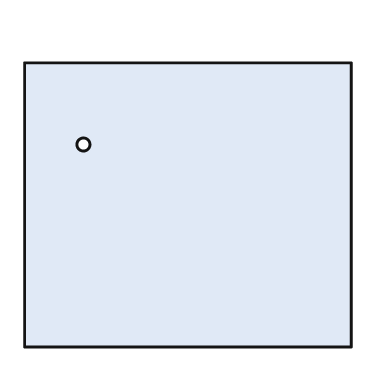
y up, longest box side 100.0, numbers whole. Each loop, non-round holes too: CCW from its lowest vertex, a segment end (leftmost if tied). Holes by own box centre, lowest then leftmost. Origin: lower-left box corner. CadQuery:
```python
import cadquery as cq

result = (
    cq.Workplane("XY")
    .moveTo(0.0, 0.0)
    .lineTo(100.0, 0.0)
    .lineTo(100.0, 87.0)
    .lineTo(0.0, 87.0)
    .close()
    .moveTo(18.0, 62.0)
    .circle(2.0)
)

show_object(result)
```